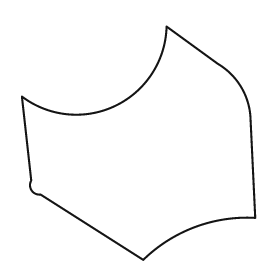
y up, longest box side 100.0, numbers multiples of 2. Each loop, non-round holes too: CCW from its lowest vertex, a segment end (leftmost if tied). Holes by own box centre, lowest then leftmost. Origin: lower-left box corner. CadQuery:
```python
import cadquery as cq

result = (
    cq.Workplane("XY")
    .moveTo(52.0, 0.0)
    .threePointArc((74.0, 14.0), (100.0, 18.0))
    .lineTo(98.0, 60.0)
    .threePointArc((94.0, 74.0), (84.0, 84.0))
    .lineTo(62.0, 100.0)
    .threePointArc((40.0, 66.0), (0.0, 70.0))
    .lineTo(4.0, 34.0)
    .threePointArc((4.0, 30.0), (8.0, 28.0))
    .close()
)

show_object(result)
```